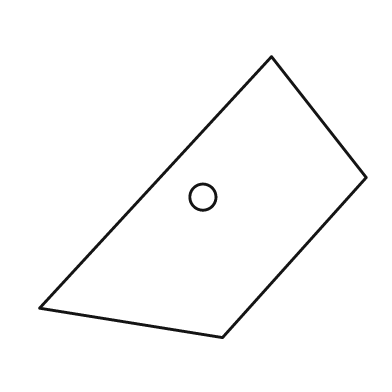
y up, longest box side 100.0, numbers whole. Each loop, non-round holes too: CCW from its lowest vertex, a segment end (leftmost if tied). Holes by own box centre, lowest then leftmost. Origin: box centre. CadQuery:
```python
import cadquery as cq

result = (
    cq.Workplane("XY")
    .moveTo(6.0, -43.0)
    .lineTo(50.0, 6.0)
    .lineTo(21.0, 43.0)
    .lineTo(-50.0, -34.0)
    .close()
    .moveTo(0.0, 0.0)
    .circle(4.0)
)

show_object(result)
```